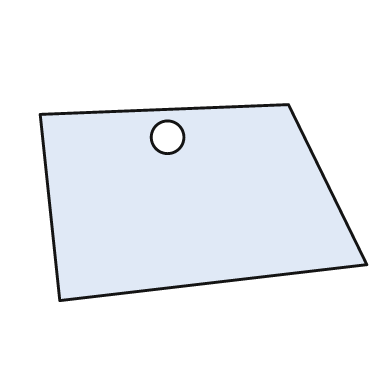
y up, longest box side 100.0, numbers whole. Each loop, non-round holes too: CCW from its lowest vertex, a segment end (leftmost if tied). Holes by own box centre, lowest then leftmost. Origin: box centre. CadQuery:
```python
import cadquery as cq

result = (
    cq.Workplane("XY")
    .moveTo(-44.0, -30.0)
    .lineTo(50.0, -19.0)
    .lineTo(26.0, 30.0)
    .lineTo(-50.0, 27.0)
    .close()
    .moveTo(-11.0, 20.0)
    .circle(5.0)
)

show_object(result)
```